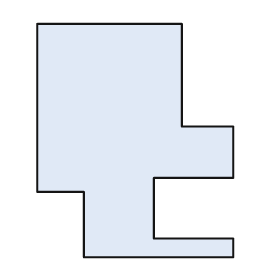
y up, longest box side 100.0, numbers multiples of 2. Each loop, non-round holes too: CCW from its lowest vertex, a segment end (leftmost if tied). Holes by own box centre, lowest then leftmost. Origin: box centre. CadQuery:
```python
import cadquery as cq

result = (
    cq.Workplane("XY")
    .moveTo(-22.0, -50.0)
    .lineTo(42.0, -50.0)
    .lineTo(42.0, -42.0)
    .lineTo(8.0, -42.0)
    .lineTo(8.0, -16.0)
    .lineTo(42.0, -16.0)
    .lineTo(42.0, 6.0)
    .lineTo(20.0, 6.0)
    .lineTo(20.0, 50.0)
    .lineTo(-42.0, 50.0)
    .lineTo(-42.0, -22.0)
    .lineTo(-22.0, -22.0)
    .close()
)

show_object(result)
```